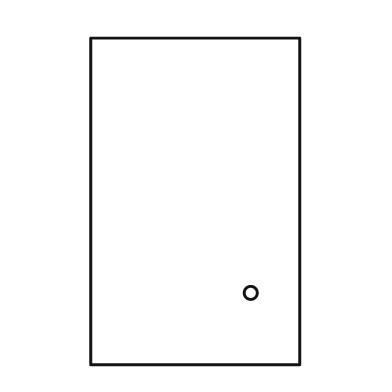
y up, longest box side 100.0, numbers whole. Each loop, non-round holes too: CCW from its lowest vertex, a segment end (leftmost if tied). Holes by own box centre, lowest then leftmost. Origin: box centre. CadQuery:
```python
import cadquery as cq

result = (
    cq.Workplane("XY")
    .moveTo(-32.0, -50.0)
    .lineTo(32.0, -50.0)
    .lineTo(32.0, 50.0)
    .lineTo(-32.0, 50.0)
    .close()
    .moveTo(17.0, -28.0)
    .circle(2.0)
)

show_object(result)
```